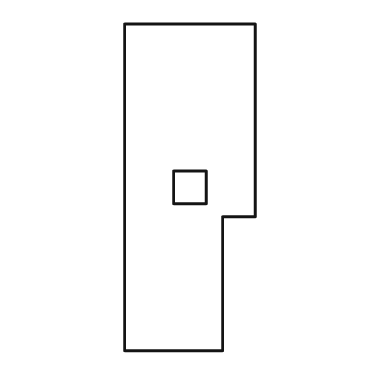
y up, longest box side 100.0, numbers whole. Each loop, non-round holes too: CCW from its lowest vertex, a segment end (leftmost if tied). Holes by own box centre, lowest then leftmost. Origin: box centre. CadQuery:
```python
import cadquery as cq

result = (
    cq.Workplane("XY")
    .moveTo(-20.0, -50.0)
    .lineTo(10.0, -50.0)
    .lineTo(10.0, -9.0)
    .lineTo(20.0, -9.0)
    .lineTo(20.0, 50.0)
    .lineTo(-20.0, 50.0)
    .close()
    .moveTo(-5.0, -5.0)
    .lineTo(5.0, -5.0)
    .lineTo(5.0, 5.0)
    .lineTo(-5.0, 5.0)
    .close()
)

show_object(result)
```